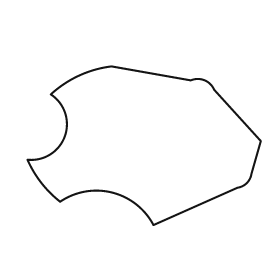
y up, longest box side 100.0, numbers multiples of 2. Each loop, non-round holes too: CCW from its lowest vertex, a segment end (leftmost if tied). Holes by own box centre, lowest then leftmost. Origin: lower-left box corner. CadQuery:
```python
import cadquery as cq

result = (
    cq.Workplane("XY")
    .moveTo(54.0, 0.0)
    .lineTo(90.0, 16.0)
    .threePointArc((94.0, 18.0), (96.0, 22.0))
    .lineTo(100.0, 36.0)
    .lineTo(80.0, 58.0)
    .threePointArc((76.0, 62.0), (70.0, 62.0))
    .lineTo(36.0, 68.0)
    .threePointArc((22.0, 64.0), (10.0, 56.0))
    .threePointArc((16.0, 38.0), (0.0, 28.0))
    .threePointArc((6.0, 18.0), (14.0, 10.0))
    .threePointArc((36.0, 14.0), (54.0, 0.0))
    .close()
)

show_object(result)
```